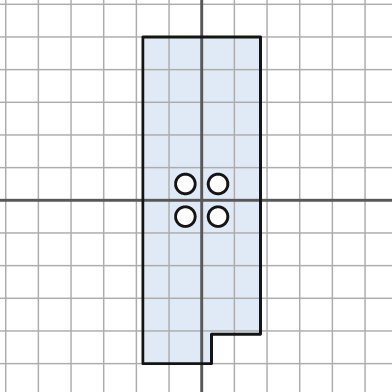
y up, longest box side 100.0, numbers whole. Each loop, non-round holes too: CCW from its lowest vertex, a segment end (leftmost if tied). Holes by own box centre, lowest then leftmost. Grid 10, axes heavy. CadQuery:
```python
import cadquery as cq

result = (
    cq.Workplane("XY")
    .moveTo(-18.0, -50.0)
    .lineTo(3.0, -50.0)
    .lineTo(3.0, -41.0)
    .lineTo(18.0, -41.0)
    .lineTo(18.0, 50.0)
    .lineTo(-18.0, 50.0)
    .close()
    .moveTo(-5.0, -5.0)
    .circle(3.0)
    .moveTo(5.0, -5.0)
    .circle(3.0)
    .moveTo(-5.0, 5.0)
    .circle(3.0)
    .moveTo(5.0, 5.0)
    .circle(3.0)
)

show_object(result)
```